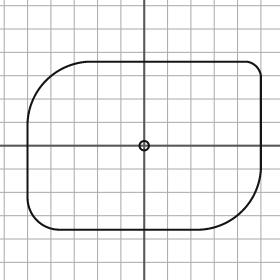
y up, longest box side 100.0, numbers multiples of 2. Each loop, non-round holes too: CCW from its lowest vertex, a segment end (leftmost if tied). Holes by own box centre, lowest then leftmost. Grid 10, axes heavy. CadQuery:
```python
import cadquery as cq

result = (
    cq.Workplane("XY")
    .moveTo(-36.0, -36.0)
    .lineTo(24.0, -36.0)
    .threePointArc((42.0, -28.0), (50.0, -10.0))
    .lineTo(50.0, 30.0)
    .threePointArc((48.0, 34.0), (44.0, 36.0))
    .lineTo(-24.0, 36.0)
    .threePointArc((-42.0, 28.0), (-50.0, 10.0))
    .lineTo(-50.0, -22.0)
    .threePointArc((-46.0, -32.0), (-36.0, -36.0))
    .close()
    .moveTo(0.0, 0.0)
    .circle(2.0)
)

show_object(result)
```